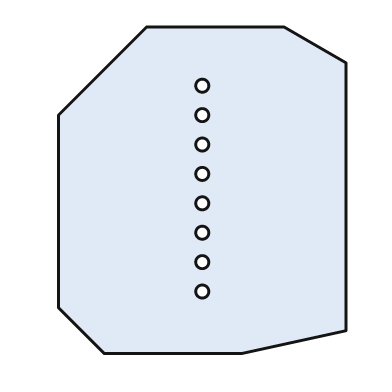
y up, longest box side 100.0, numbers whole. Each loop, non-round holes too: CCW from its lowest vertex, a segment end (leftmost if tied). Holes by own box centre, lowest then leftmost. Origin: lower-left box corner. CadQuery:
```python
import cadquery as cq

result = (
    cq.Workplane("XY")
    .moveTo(14.0, 0.0)
    .lineTo(56.0, 0.0)
    .lineTo(88.0, 7.0)
    .lineTo(88.0, 89.0)
    .lineTo(69.0, 100.0)
    .lineTo(27.0, 100.0)
    .lineTo(0.0, 73.0)
    .lineTo(0.0, 14.0)
    .close()
    .moveTo(44.0, 19.0)
    .circle(2.0)
    .moveTo(44.0, 28.0)
    .circle(2.0)
    .moveTo(44.0, 37.0)
    .circle(2.0)
    .moveTo(44.0, 46.0)
    .circle(2.0)
    .moveTo(44.0, 55.0)
    .circle(2.0)
    .moveTo(44.0, 64.0)
    .circle(2.0)
    .moveTo(44.0, 73.0)
    .circle(2.0)
    .moveTo(44.0, 82.0)
    .circle(2.0)
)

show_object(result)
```